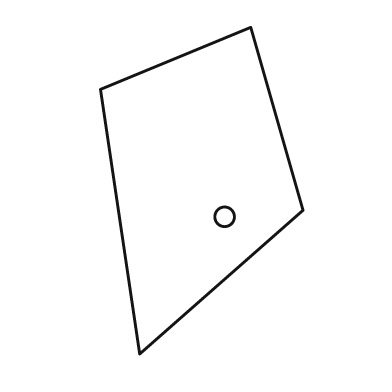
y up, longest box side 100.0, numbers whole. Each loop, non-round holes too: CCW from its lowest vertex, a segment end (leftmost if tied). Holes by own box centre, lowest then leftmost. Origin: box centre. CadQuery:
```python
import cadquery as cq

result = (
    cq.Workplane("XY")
    .moveTo(-19.0, -50.0)
    .lineTo(31.0, -6.0)
    .lineTo(15.0, 50.0)
    .lineTo(-31.0, 31.0)
    .close()
    .moveTo(7.0, -8.0)
    .circle(3.0)
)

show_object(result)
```